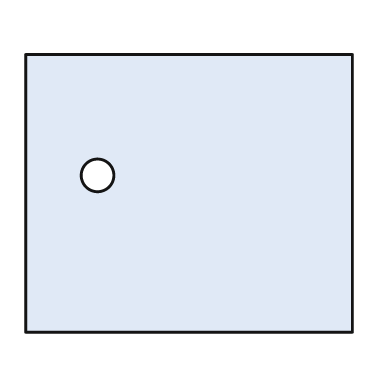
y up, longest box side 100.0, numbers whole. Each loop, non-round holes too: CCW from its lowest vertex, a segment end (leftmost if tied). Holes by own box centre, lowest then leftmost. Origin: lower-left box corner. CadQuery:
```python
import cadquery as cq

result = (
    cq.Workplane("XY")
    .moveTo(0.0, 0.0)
    .lineTo(100.0, 0.0)
    .lineTo(100.0, 85.0)
    .lineTo(0.0, 85.0)
    .close()
    .moveTo(22.0, 48.0)
    .circle(5.0)
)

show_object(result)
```